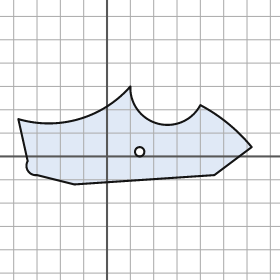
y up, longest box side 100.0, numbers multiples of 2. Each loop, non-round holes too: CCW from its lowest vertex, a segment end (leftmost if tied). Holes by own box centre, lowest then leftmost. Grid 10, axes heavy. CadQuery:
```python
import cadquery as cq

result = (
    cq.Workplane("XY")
    .moveTo(-14.0, -12.0)
    .lineTo(46.0, -8.0)
    .lineTo(62.0, 4.0)
    .threePointArc((52.0, 14.0), (40.0, 22.0))
    .threePointArc((22.0, 14.0), (10.0, 30.0))
    .threePointArc((-12.0, 16.0), (-38.0, 16.0))
    .lineTo(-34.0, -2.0)
    .threePointArc((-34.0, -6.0), (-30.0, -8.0))
    .close()
    .moveTo(14.0, 2.0)
    .circle(2.0)
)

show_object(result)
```